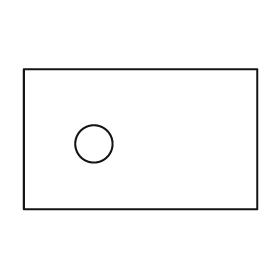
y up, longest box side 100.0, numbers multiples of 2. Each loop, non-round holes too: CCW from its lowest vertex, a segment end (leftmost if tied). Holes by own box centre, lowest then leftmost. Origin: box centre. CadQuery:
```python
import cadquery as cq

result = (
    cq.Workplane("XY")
    .moveTo(-50.0, -30.0)
    .lineTo(50.0, -30.0)
    .lineTo(50.0, 30.0)
    .lineTo(-50.0, 30.0)
    .close()
    .moveTo(-20.0, -2.0)
    .circle(8.0)
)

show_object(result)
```